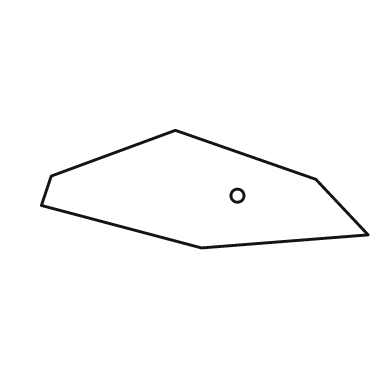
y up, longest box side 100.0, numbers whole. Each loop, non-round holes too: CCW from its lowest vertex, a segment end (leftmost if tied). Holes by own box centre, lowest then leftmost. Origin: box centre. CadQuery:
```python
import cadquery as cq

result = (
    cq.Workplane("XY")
    .moveTo(-1.0, -18.0)
    .lineTo(50.0, -14.0)
    .lineTo(34.0, 3.0)
    .lineTo(-9.0, 18.0)
    .lineTo(-47.0, 4.0)
    .lineTo(-50.0, -5.0)
    .close()
    .moveTo(10.0, -2.0)
    .circle(2.0)
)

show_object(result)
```